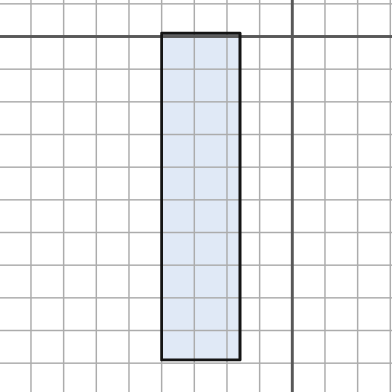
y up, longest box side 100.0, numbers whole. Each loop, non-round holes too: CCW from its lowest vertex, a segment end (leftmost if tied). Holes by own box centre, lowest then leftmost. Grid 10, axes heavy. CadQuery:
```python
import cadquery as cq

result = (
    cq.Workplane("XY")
    .moveTo(-40.0, -99.0)
    .lineTo(-16.0, -99.0)
    .lineTo(-16.0, 1.0)
    .lineTo(-40.0, 1.0)
    .close()
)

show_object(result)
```